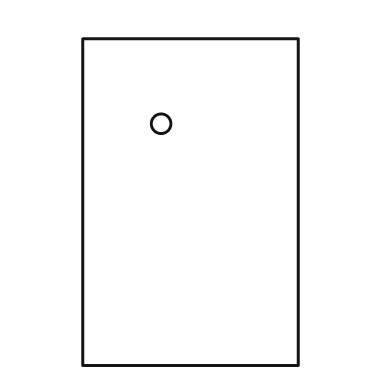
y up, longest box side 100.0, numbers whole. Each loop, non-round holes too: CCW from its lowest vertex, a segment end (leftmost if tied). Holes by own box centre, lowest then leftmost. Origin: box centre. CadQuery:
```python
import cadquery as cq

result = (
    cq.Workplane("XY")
    .moveTo(-33.0, -50.0)
    .lineTo(33.0, -50.0)
    .lineTo(33.0, 50.0)
    .lineTo(-33.0, 50.0)
    .close()
    .moveTo(-9.0, 24.0)
    .circle(3.0)
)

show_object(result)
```